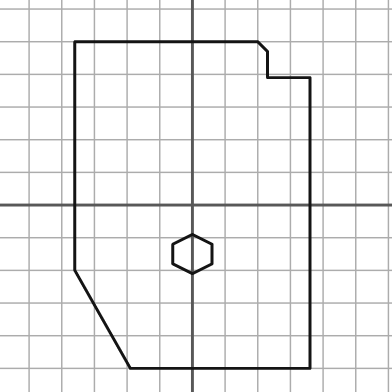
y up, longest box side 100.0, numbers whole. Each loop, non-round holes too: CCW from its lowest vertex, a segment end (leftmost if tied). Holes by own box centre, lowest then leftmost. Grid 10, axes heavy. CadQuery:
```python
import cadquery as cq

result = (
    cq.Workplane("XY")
    .moveTo(-19.0, -50.0)
    .lineTo(36.0, -50.0)
    .lineTo(36.0, 39.0)
    .lineTo(23.0, 39.0)
    .lineTo(23.0, 47.0)
    .lineTo(20.0, 50.0)
    .lineTo(-36.0, 50.0)
    .lineTo(-36.0, -20.0)
    .close()
    .moveTo(0.0, -21.0)
    .lineTo(6.0, -18.0)
    .lineTo(6.0, -12.0)
    .lineTo(0.0, -9.0)
    .lineTo(-6.0, -12.0)
    .lineTo(-6.0, -18.0)
    .close()
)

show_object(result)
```